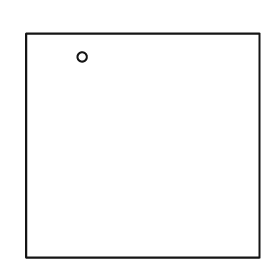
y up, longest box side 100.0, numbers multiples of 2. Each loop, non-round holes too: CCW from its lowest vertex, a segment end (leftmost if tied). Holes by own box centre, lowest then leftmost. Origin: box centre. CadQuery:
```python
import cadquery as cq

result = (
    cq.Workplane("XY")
    .moveTo(-50.0, -48.0)
    .lineTo(50.0, -48.0)
    .lineTo(50.0, 48.0)
    .lineTo(-50.0, 48.0)
    .close()
    .moveTo(-26.0, 38.0)
    .circle(2.0)
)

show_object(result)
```